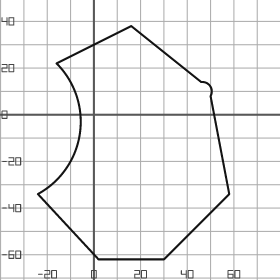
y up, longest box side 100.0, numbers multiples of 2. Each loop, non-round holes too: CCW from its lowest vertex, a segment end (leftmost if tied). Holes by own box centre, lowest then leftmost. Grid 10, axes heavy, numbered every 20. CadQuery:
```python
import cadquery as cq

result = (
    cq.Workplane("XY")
    .moveTo(2.0, -62.0)
    .lineTo(30.0, -62.0)
    .lineTo(58.0, -34.0)
    .lineTo(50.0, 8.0)
    .threePointArc((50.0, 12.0), (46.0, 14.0))
    .lineTo(16.0, 38.0)
    .lineTo(-16.0, 22.0)
    .threePointArc((-6.0, -8.0), (-24.0, -34.0))
    .close()
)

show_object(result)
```